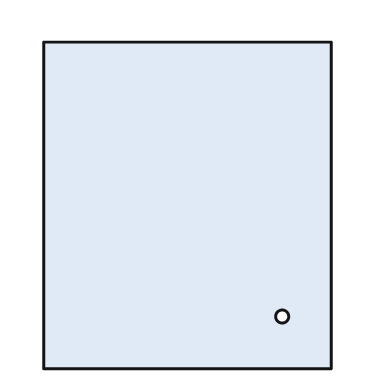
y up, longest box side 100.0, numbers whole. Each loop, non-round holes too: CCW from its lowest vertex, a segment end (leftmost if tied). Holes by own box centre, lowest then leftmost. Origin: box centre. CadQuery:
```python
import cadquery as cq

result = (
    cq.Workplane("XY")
    .moveTo(-44.0, -50.0)
    .lineTo(44.0, -50.0)
    .lineTo(44.0, 50.0)
    .lineTo(-44.0, 50.0)
    .close()
    .moveTo(29.0, -34.0)
    .circle(2.0)
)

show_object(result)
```